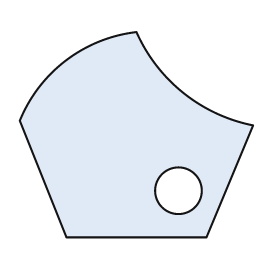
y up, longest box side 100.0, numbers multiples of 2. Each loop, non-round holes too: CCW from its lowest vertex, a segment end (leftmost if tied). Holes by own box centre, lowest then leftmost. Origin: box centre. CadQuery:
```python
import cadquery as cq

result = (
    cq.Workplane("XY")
    .moveTo(-30.0, -44.0)
    .lineTo(30.0, -44.0)
    .lineTo(50.0, 4.0)
    .threePointArc((20.0, 18.0), (0.0, 44.0))
    .threePointArc((-30.0, 32.0), (-50.0, 6.0))
    .close()
    .moveTo(18.0, -24.0)
    .circle(10.0)
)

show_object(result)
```